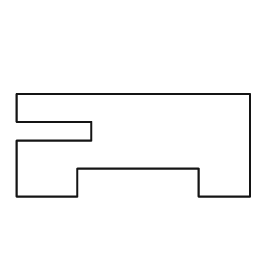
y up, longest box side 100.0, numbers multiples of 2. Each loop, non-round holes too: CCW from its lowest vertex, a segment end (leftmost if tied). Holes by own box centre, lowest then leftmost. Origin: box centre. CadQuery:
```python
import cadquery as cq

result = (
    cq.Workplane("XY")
    .moveTo(-50.0, -22.0)
    .lineTo(-24.0, -22.0)
    .lineTo(-24.0, -10.0)
    .lineTo(28.0, -10.0)
    .lineTo(28.0, -22.0)
    .lineTo(50.0, -22.0)
    .lineTo(50.0, 22.0)
    .lineTo(-50.0, 22.0)
    .lineTo(-50.0, 10.0)
    .lineTo(-18.0, 10.0)
    .lineTo(-18.0, 2.0)
    .lineTo(-50.0, 2.0)
    .close()
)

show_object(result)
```